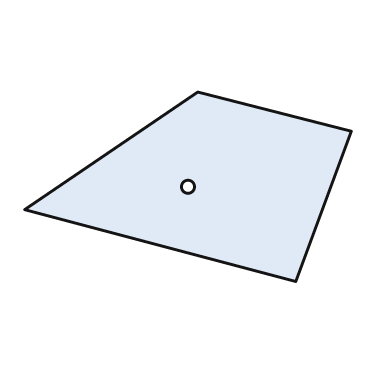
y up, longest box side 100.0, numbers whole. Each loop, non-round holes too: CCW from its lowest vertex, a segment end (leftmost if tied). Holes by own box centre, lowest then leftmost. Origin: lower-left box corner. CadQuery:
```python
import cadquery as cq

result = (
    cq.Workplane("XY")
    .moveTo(83.0, 0.0)
    .lineTo(100.0, 46.0)
    .lineTo(53.0, 58.0)
    .lineTo(0.0, 22.0)
    .close()
    .moveTo(50.0, 29.0)
    .circle(2.0)
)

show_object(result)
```